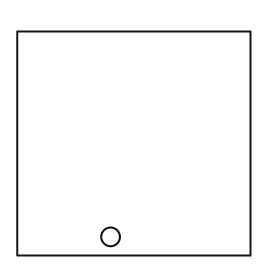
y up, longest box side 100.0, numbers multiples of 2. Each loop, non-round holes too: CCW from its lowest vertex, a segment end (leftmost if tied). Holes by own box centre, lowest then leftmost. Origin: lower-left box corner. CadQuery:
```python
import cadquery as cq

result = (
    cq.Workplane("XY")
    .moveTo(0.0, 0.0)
    .lineTo(100.0, 0.0)
    .lineTo(100.0, 96.0)
    .lineTo(0.0, 96.0)
    .close()
    .moveTo(40.0, 8.0)
    .circle(4.0)
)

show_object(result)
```